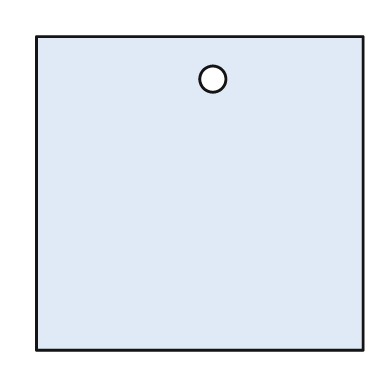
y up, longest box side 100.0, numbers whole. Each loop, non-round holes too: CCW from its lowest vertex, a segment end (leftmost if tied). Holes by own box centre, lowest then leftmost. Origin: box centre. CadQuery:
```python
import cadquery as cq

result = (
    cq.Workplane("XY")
    .moveTo(-50.0, -48.0)
    .lineTo(50.0, -48.0)
    .lineTo(50.0, 48.0)
    .lineTo(-50.0, 48.0)
    .close()
    .moveTo(4.0, 35.0)
    .circle(4.0)
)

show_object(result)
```